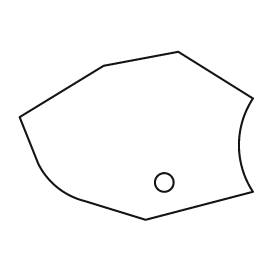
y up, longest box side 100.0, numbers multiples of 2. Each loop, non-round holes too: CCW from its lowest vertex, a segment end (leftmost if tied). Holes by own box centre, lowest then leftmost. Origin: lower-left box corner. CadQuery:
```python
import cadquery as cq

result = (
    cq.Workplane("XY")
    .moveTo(54.0, 0.0)
    .lineTo(100.0, 12.0)
    .threePointArc((94.0, 32.0), (100.0, 52.0))
    .lineTo(68.0, 72.0)
    .lineTo(36.0, 66.0)
    .lineTo(0.0, 44.0)
    .lineTo(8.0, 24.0)
    .threePointArc((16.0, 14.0), (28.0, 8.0))
    .close()
    .moveTo(62.0, 16.0)
    .circle(4.0)
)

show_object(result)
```